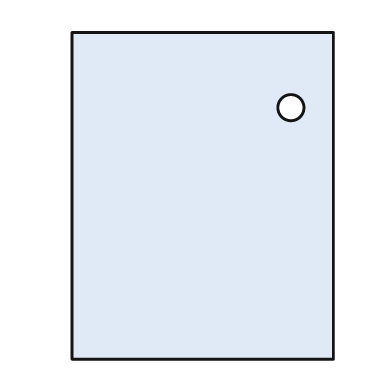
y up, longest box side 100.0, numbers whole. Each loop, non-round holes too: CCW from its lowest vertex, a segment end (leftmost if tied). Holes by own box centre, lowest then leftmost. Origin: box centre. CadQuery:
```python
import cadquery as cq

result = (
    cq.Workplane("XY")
    .moveTo(-40.0, -50.0)
    .lineTo(40.0, -50.0)
    .lineTo(40.0, 50.0)
    .lineTo(-40.0, 50.0)
    .close()
    .moveTo(27.0, 27.0)
    .circle(4.0)
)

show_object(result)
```